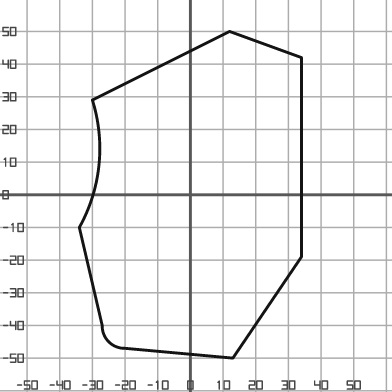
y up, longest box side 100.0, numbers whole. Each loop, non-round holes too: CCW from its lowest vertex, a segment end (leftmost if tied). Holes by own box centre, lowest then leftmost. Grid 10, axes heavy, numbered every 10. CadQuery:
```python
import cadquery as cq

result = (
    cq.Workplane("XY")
    .moveTo(13.0, -50.0)
    .lineTo(34.0, -19.0)
    .lineTo(34.0, 42.0)
    .lineTo(12.0, 50.0)
    .lineTo(-30.0, 29.0)
    .threePointArc((-28.0, 9.0), (-34.0, -10.0))
    .lineTo(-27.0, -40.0)
    .threePointArc((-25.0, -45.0), (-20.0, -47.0))
    .close()
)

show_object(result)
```